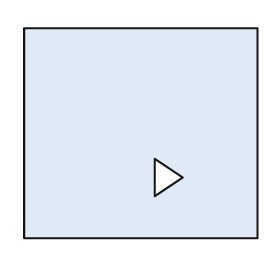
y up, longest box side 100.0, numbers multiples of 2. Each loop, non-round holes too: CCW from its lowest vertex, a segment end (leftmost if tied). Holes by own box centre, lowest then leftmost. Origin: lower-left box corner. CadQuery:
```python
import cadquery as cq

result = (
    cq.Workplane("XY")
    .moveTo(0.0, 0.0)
    .lineTo(100.0, 0.0)
    .lineTo(100.0, 90.0)
    .lineTo(0.0, 90.0)
    .close()
    .moveTo(56.0, 18.0)
    .lineTo(68.0, 26.0)
    .lineTo(56.0, 34.0)
    .close()
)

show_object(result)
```